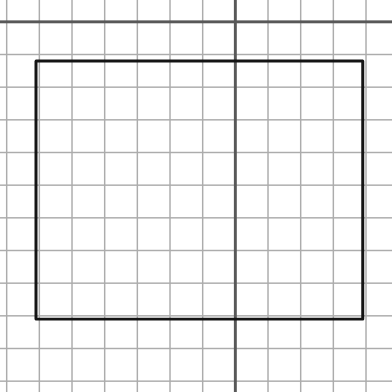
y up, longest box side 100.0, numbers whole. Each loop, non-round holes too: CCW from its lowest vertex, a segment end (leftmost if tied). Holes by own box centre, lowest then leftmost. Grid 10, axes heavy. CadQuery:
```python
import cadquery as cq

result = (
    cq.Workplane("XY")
    .moveTo(-61.0, -91.0)
    .lineTo(39.0, -91.0)
    .lineTo(39.0, -12.0)
    .lineTo(-61.0, -12.0)
    .close()
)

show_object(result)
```